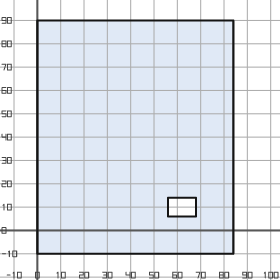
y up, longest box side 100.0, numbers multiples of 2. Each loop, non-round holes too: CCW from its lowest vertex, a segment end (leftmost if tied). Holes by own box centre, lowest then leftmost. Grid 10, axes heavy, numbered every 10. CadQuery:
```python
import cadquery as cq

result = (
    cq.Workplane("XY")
    .moveTo(0.0, -10.0)
    .lineTo(84.0, -10.0)
    .lineTo(84.0, 90.0)
    .lineTo(0.0, 90.0)
    .close()
    .moveTo(56.0, 6.0)
    .lineTo(68.0, 6.0)
    .lineTo(68.0, 14.0)
    .lineTo(56.0, 14.0)
    .close()
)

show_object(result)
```